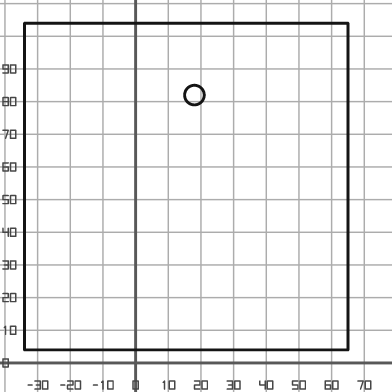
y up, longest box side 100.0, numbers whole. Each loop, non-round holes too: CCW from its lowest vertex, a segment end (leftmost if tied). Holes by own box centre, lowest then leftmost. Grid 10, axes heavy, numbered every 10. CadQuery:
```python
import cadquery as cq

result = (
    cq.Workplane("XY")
    .moveTo(-34.0, 4.0)
    .lineTo(65.0, 4.0)
    .lineTo(65.0, 104.0)
    .lineTo(-34.0, 104.0)
    .close()
    .moveTo(18.0, 82.0)
    .circle(3.0)
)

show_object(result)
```